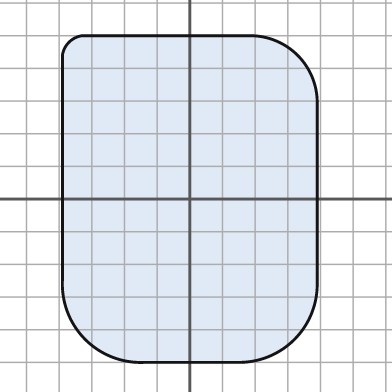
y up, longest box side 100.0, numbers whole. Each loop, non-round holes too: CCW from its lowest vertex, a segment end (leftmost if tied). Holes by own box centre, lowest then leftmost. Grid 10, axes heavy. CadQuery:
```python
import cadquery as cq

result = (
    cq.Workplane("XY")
    .moveTo(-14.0, -50.0)
    .lineTo(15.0, -50.0)
    .threePointArc((32.0, -43.0), (39.0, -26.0))
    .lineTo(39.0, 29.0)
    .threePointArc((33.0, 44.0), (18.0, 50.0))
    .lineTo(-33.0, 50.0)
    .threePointArc((-37.0, 48.0), (-39.0, 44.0))
    .lineTo(-39.0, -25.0)
    .threePointArc((-32.0, -43.0), (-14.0, -50.0))
    .close()
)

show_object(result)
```